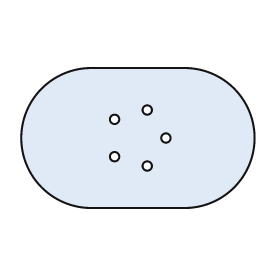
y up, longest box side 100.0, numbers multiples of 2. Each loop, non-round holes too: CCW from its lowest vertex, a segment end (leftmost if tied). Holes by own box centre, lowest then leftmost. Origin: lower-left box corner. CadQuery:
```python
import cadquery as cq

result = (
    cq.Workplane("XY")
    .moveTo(30.0, 0.0)
    .lineTo(70.0, 0.0)
    .threePointArc((100.0, 30.0), (70.0, 60.0))
    .lineTo(30.0, 60.0)
    .threePointArc((0.0, 30.0), (30.0, 0.0))
    .close()
    .moveTo(54.0, 18.0)
    .circle(2.0)
    .moveTo(40.0, 22.0)
    .circle(2.0)
    .moveTo(62.0, 30.0)
    .circle(2.0)
    .moveTo(40.0, 38.0)
    .circle(2.0)
    .moveTo(54.0, 42.0)
    .circle(2.0)
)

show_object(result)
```